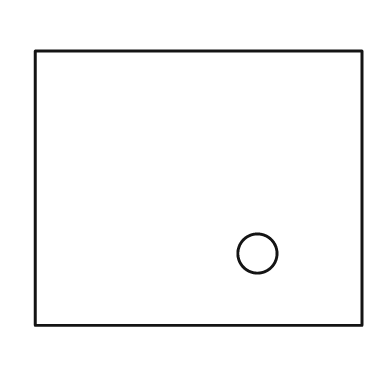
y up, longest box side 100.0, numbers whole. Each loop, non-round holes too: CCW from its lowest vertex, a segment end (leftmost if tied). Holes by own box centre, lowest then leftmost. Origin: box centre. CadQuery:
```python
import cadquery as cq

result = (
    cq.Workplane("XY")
    .moveTo(-50.0, -42.0)
    .lineTo(50.0, -42.0)
    .lineTo(50.0, 42.0)
    .lineTo(-50.0, 42.0)
    .close()
    .moveTo(18.0, -20.0)
    .circle(6.0)
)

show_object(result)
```